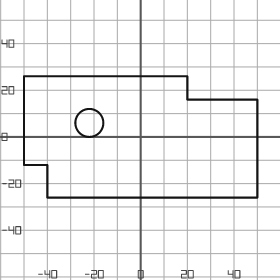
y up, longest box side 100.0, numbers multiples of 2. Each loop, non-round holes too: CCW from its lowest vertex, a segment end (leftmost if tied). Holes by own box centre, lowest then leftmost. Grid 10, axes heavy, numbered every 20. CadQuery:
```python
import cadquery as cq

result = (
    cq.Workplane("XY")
    .moveTo(-40.0, -26.0)
    .lineTo(50.0, -26.0)
    .lineTo(50.0, 16.0)
    .lineTo(20.0, 16.0)
    .lineTo(20.0, 26.0)
    .lineTo(-50.0, 26.0)
    .lineTo(-50.0, -12.0)
    .lineTo(-40.0, -12.0)
    .close()
    .moveTo(-22.0, 6.0)
    .circle(6.0)
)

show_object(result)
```